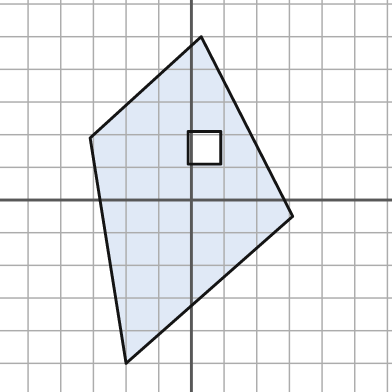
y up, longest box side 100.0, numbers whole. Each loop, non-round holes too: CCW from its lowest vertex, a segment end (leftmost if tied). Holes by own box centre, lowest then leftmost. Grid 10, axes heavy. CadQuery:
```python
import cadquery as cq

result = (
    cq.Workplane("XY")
    .moveTo(-20.0, -50.0)
    .lineTo(31.0, -5.0)
    .lineTo(3.0, 50.0)
    .lineTo(-31.0, 19.0)
    .close()
    .moveTo(-1.0, 11.0)
    .lineTo(9.0, 11.0)
    .lineTo(9.0, 21.0)
    .lineTo(-1.0, 21.0)
    .close()
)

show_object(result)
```